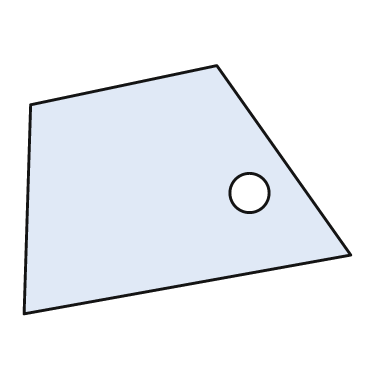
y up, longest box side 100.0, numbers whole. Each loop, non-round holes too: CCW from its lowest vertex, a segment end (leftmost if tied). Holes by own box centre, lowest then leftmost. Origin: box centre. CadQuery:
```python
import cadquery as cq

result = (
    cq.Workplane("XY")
    .moveTo(-50.0, -38.0)
    .lineTo(50.0, -20.0)
    .lineTo(9.0, 38.0)
    .lineTo(-48.0, 26.0)
    .close()
    .moveTo(19.0, -1.0)
    .circle(6.0)
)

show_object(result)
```